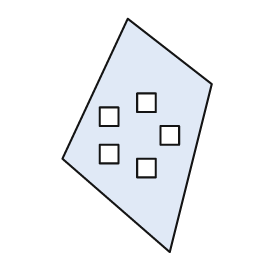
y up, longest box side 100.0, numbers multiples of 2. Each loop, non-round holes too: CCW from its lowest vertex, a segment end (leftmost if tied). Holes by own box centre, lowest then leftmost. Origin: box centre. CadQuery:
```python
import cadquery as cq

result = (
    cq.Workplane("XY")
    .moveTo(14.0, -50.0)
    .lineTo(32.0, 22.0)
    .lineTo(-4.0, 50.0)
    .lineTo(-32.0, -10.0)
    .close()
    .moveTo(0.0, -18.0)
    .lineTo(8.0, -18.0)
    .lineTo(8.0, -10.0)
    .lineTo(0.0, -10.0)
    .close()
    .moveTo(-16.0, -12.0)
    .lineTo(-8.0, -12.0)
    .lineTo(-8.0, -4.0)
    .lineTo(-16.0, -4.0)
    .close()
    .moveTo(10.0, -4.0)
    .lineTo(18.0, -4.0)
    .lineTo(18.0, 4.0)
    .lineTo(10.0, 4.0)
    .close()
    .moveTo(-16.0, 4.0)
    .lineTo(-8.0, 4.0)
    .lineTo(-8.0, 12.0)
    .lineTo(-16.0, 12.0)
    .close()
    .moveTo(0.0, 10.0)
    .lineTo(8.0, 10.0)
    .lineTo(8.0, 18.0)
    .lineTo(0.0, 18.0)
    .close()
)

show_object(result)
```